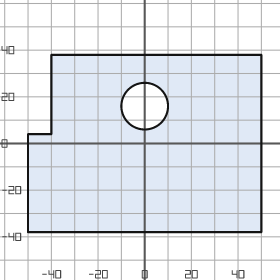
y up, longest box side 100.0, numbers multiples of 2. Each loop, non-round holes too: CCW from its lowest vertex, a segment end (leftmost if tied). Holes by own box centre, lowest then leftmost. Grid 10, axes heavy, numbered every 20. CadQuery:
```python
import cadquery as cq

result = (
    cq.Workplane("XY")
    .moveTo(-50.0, -38.0)
    .lineTo(50.0, -38.0)
    .lineTo(50.0, 38.0)
    .lineTo(-40.0, 38.0)
    .lineTo(-40.0, 4.0)
    .lineTo(-50.0, 4.0)
    .close()
    .moveTo(0.0, 16.0)
    .circle(10.0)
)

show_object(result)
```